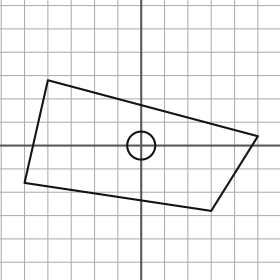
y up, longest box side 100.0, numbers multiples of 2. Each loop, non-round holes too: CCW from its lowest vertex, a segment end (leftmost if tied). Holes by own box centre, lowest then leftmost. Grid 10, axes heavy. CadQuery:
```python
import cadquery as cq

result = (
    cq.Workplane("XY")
    .moveTo(30.0, -28.0)
    .lineTo(50.0, 4.0)
    .lineTo(-40.0, 28.0)
    .lineTo(-50.0, -16.0)
    .close()
    .moveTo(0.0, 0.0)
    .circle(6.0)
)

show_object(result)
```